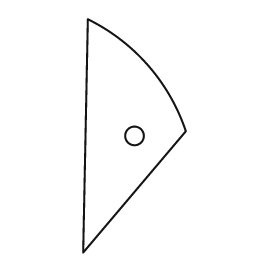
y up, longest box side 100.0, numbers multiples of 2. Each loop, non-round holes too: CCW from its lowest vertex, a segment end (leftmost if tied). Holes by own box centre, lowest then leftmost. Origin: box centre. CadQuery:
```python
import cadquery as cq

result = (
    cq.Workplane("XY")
    .moveTo(-22.0, -50.0)
    .lineTo(22.0, 2.0)
    .threePointArc((6.0, 30.0), (-20.0, 50.0))
    .close()
    .moveTo(0.0, 0.0)
    .circle(4.0)
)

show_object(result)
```